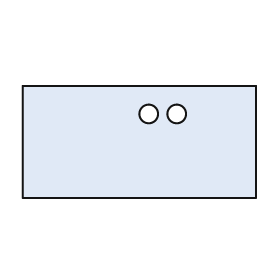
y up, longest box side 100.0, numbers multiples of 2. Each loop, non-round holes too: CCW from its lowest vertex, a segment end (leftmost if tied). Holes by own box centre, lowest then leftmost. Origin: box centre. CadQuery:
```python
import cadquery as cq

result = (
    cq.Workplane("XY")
    .moveTo(-50.0, -24.0)
    .lineTo(50.0, -24.0)
    .lineTo(50.0, 24.0)
    .lineTo(-50.0, 24.0)
    .close()
    .moveTo(4.0, 12.0)
    .circle(4.0)
    .moveTo(16.0, 12.0)
    .circle(4.0)
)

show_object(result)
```